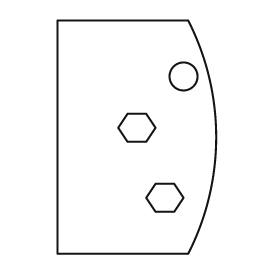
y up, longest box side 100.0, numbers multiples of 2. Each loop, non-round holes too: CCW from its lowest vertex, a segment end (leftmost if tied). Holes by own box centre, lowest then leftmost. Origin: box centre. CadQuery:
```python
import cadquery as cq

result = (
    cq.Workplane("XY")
    .moveTo(-34.0, -50.0)
    .lineTo(22.0, -50.0)
    .threePointArc((34.0, 0.0), (22.0, 50.0))
    .lineTo(-34.0, 50.0)
    .close()
    .moveTo(8.0, -32.0)
    .lineTo(16.0, -32.0)
    .lineTo(20.0, -26.0)
    .lineTo(16.0, -20.0)
    .lineTo(8.0, -20.0)
    .lineTo(4.0, -26.0)
    .close()
    .moveTo(-4.0, -2.0)
    .lineTo(4.0, -2.0)
    .lineTo(8.0, 4.0)
    .lineTo(4.0, 10.0)
    .lineTo(-4.0, 10.0)
    .lineTo(-8.0, 4.0)
    .close()
    .moveTo(20.0, 26.0)
    .circle(6.0)
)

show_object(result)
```